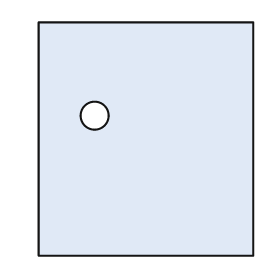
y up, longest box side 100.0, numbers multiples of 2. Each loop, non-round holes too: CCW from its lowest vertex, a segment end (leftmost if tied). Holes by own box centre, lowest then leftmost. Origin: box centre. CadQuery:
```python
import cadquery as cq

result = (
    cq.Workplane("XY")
    .moveTo(-46.0, -50.0)
    .lineTo(46.0, -50.0)
    .lineTo(46.0, 50.0)
    .lineTo(-46.0, 50.0)
    .close()
    .moveTo(-22.0, 10.0)
    .circle(6.0)
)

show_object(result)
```